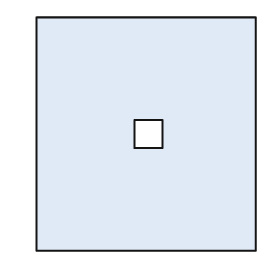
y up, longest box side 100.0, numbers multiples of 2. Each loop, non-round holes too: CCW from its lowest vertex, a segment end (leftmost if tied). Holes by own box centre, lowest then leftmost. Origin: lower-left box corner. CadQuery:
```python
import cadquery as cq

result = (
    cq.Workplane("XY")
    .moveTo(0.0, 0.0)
    .lineTo(94.0, 0.0)
    .lineTo(94.0, 100.0)
    .lineTo(0.0, 100.0)
    .close()
    .moveTo(42.0, 44.0)
    .lineTo(54.0, 44.0)
    .lineTo(54.0, 56.0)
    .lineTo(42.0, 56.0)
    .close()
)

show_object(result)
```